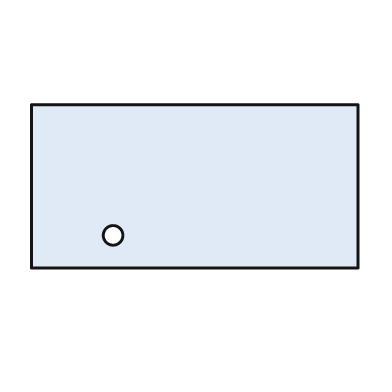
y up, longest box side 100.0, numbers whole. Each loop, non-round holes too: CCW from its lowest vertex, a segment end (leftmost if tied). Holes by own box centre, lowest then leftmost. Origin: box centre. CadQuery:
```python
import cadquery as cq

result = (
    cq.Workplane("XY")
    .moveTo(-50.0, -25.0)
    .lineTo(50.0, -25.0)
    .lineTo(50.0, 25.0)
    .lineTo(-50.0, 25.0)
    .close()
    .moveTo(-25.0, -15.0)
    .circle(3.0)
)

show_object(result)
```